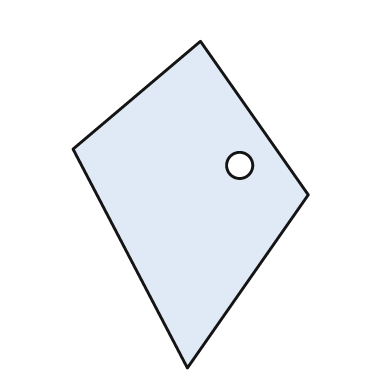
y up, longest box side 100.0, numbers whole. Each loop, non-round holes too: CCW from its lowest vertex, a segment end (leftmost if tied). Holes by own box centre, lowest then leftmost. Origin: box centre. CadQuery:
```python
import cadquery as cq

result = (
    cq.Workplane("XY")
    .moveTo(-1.0, -50.0)
    .lineTo(36.0, 3.0)
    .lineTo(3.0, 50.0)
    .lineTo(-36.0, 17.0)
    .close()
    .moveTo(15.0, 12.0)
    .circle(4.0)
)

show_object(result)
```